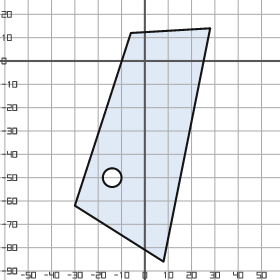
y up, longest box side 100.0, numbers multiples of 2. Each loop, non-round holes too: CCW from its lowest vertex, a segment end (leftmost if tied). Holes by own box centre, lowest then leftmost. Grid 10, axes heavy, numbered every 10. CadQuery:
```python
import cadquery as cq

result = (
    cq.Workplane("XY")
    .moveTo(8.0, -86.0)
    .lineTo(28.0, 14.0)
    .lineTo(-6.0, 12.0)
    .lineTo(-30.0, -62.0)
    .close()
    .moveTo(-14.0, -50.0)
    .circle(4.0)
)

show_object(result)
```